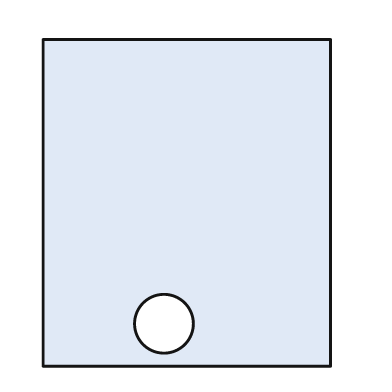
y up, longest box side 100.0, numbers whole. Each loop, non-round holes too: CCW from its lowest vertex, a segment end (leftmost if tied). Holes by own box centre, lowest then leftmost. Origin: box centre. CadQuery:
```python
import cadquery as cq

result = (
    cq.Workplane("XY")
    .moveTo(-44.0, -50.0)
    .lineTo(44.0, -50.0)
    .lineTo(44.0, 50.0)
    .lineTo(-44.0, 50.0)
    .close()
    .moveTo(-7.0, -37.0)
    .circle(9.0)
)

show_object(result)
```